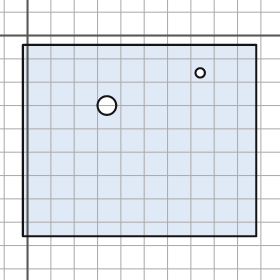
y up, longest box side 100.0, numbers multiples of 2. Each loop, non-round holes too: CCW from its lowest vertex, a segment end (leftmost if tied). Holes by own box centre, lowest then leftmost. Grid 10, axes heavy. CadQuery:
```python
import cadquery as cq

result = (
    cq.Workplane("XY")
    .moveTo(-2.0, -86.0)
    .lineTo(98.0, -86.0)
    .lineTo(98.0, -4.0)
    .lineTo(-2.0, -4.0)
    .close()
    .moveTo(34.0, -30.0)
    .circle(4.0)
    .moveTo(74.0, -16.0)
    .circle(2.0)
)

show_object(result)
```